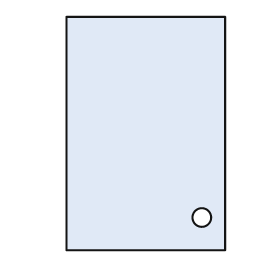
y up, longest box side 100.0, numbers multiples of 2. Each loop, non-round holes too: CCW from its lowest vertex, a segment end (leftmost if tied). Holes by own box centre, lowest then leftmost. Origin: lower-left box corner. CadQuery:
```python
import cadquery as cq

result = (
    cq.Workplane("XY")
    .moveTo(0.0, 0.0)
    .lineTo(68.0, 0.0)
    .lineTo(68.0, 100.0)
    .lineTo(0.0, 100.0)
    .close()
    .moveTo(58.0, 14.0)
    .circle(4.0)
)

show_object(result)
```